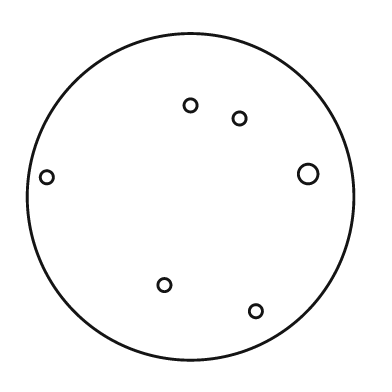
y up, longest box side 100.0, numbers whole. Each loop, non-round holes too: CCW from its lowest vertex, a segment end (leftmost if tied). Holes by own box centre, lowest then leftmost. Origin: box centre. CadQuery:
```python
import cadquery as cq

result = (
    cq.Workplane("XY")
    .moveTo(0.0, 0.0)
    .circle(50.0)
    .moveTo(20.0, -35.0)
    .circle(2.0)
    .moveTo(-8.0, -27.0)
    .circle(2.0)
    .moveTo(-44.0, 6.0)
    .circle(2.0)
    .moveTo(36.0, 7.0)
    .circle(3.0)
    .moveTo(15.0, 24.0)
    .circle(2.0)
    .moveTo(0.0, 28.0)
    .circle(2.0)
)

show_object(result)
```